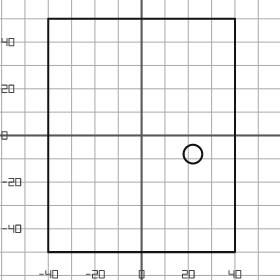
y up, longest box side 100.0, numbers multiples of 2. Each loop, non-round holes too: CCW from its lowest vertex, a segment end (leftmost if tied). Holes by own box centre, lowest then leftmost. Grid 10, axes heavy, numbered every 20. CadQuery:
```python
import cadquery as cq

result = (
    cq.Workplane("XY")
    .moveTo(-40.0, -50.0)
    .lineTo(40.0, -50.0)
    .lineTo(40.0, 50.0)
    .lineTo(-40.0, 50.0)
    .close()
    .moveTo(22.0, -8.0)
    .circle(4.0)
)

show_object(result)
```